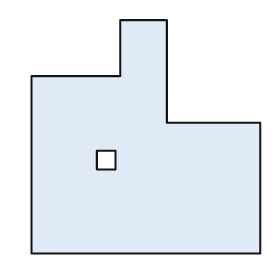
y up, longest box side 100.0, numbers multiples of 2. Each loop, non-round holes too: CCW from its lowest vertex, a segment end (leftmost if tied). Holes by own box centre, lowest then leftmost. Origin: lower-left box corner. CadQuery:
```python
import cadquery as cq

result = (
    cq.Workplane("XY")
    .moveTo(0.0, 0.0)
    .lineTo(98.0, 0.0)
    .lineTo(98.0, 56.0)
    .lineTo(58.0, 56.0)
    .lineTo(58.0, 100.0)
    .lineTo(38.0, 100.0)
    .lineTo(38.0, 76.0)
    .lineTo(0.0, 76.0)
    .close()
    .moveTo(28.0, 36.0)
    .lineTo(36.0, 36.0)
    .lineTo(36.0, 44.0)
    .lineTo(28.0, 44.0)
    .close()
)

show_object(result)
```